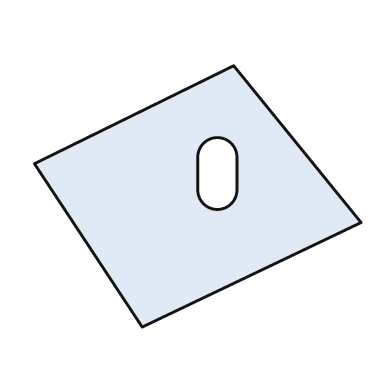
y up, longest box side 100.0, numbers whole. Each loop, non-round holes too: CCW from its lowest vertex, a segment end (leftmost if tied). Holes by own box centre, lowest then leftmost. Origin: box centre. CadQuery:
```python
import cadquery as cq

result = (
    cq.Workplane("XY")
    .moveTo(-17.0, -40.0)
    .lineTo(50.0, -8.0)
    .lineTo(11.0, 40.0)
    .lineTo(-50.0, 10.0)
    .close()
    .moveTo(0.0, 2.0)
    .threePointArc((6.0, -4.0), (12.0, 2.0))
    .lineTo(12.0, 12.0)
    .threePointArc((6.0, 18.0), (0.0, 12.0))
    .close()
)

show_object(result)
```